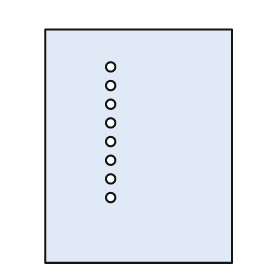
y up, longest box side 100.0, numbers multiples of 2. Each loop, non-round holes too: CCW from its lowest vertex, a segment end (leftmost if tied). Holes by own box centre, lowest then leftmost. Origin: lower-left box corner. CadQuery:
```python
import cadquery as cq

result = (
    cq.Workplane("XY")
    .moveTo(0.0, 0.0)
    .lineTo(80.0, 0.0)
    .lineTo(80.0, 100.0)
    .lineTo(0.0, 100.0)
    .close()
    .moveTo(28.0, 28.0)
    .circle(2.0)
    .moveTo(28.0, 36.0)
    .circle(2.0)
    .moveTo(28.0, 44.0)
    .circle(2.0)
    .moveTo(28.0, 52.0)
    .circle(2.0)
    .moveTo(28.0, 60.0)
    .circle(2.0)
    .moveTo(28.0, 68.0)
    .circle(2.0)
    .moveTo(28.0, 76.0)
    .circle(2.0)
    .moveTo(28.0, 84.0)
    .circle(2.0)
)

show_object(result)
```